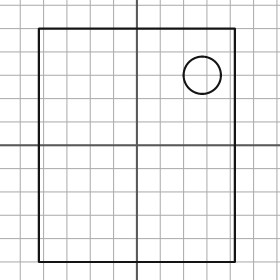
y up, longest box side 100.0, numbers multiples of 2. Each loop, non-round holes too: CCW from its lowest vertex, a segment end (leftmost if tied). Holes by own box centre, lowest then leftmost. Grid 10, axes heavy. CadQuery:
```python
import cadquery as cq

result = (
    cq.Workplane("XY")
    .moveTo(-42.0, -50.0)
    .lineTo(42.0, -50.0)
    .lineTo(42.0, 50.0)
    .lineTo(-42.0, 50.0)
    .close()
    .moveTo(28.0, 30.0)
    .circle(8.0)
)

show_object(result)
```